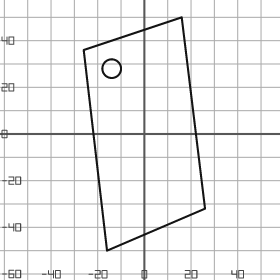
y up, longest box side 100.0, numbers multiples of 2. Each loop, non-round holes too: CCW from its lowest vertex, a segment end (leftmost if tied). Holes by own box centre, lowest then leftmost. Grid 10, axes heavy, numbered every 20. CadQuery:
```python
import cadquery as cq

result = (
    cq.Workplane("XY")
    .moveTo(-16.0, -50.0)
    .lineTo(26.0, -32.0)
    .lineTo(16.0, 50.0)
    .lineTo(-26.0, 36.0)
    .close()
    .moveTo(-14.0, 28.0)
    .circle(4.0)
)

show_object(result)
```